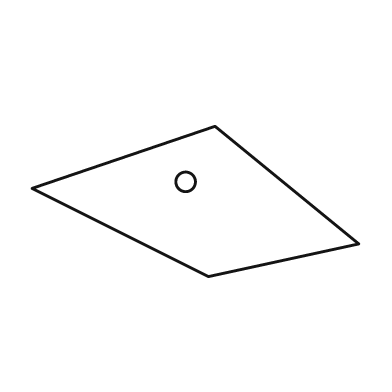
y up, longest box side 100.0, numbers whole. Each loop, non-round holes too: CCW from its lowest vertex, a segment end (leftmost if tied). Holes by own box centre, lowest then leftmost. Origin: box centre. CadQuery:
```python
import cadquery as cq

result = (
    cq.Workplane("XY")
    .moveTo(4.0, -23.0)
    .lineTo(50.0, -13.0)
    .lineTo(6.0, 23.0)
    .lineTo(-50.0, 4.0)
    .close()
    .moveTo(-3.0, 6.0)
    .circle(3.0)
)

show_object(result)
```